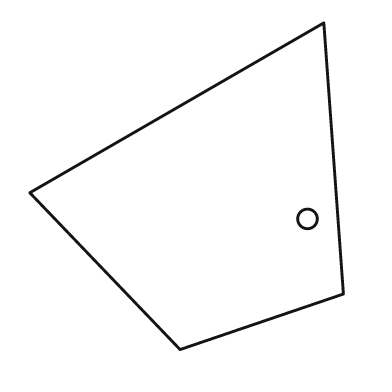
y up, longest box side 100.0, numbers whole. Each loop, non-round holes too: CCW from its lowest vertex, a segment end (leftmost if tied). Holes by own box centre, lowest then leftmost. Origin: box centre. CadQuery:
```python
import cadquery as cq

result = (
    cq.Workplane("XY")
    .moveTo(-2.0, -50.0)
    .lineTo(48.0, -33.0)
    .lineTo(42.0, 50.0)
    .lineTo(-48.0, -2.0)
    .close()
    .moveTo(37.0, -10.0)
    .circle(3.0)
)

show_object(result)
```